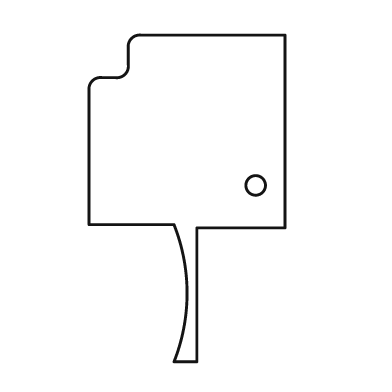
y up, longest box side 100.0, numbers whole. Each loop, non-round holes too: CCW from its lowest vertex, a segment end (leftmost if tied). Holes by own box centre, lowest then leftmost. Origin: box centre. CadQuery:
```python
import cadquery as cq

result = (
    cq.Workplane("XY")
    .moveTo(-4.0, -50.0)
    .lineTo(3.0, -50.0)
    .lineTo(3.0, -9.0)
    .lineTo(30.0, -9.0)
    .lineTo(30.0, 50.0)
    .lineTo(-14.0, 50.0)
    .threePointArc((-17.0, 49.0), (-18.0, 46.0))
    .lineTo(-18.0, 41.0)
    .threePointArc((-19.0, 38.0), (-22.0, 37.0))
    .lineTo(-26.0, 37.0)
    .threePointArc((-29.0, 36.0), (-30.0, 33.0))
    .lineTo(-30.0, -8.0)
    .lineTo(-4.0, -8.0)
    .threePointArc((0.0, -29.0), (-4.0, -50.0))
    .close()
    .moveTo(21.0, 4.0)
    .circle(3.0)
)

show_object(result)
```